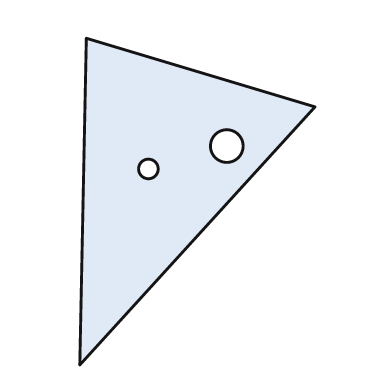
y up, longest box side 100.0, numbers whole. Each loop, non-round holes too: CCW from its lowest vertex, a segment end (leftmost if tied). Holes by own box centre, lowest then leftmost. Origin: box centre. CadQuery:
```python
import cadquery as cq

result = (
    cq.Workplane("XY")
    .moveTo(-36.0, -50.0)
    .lineTo(36.0, 29.0)
    .lineTo(-34.0, 50.0)
    .close()
    .moveTo(-15.0, 10.0)
    .circle(3.0)
    .moveTo(9.0, 17.0)
    .circle(5.0)
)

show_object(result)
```